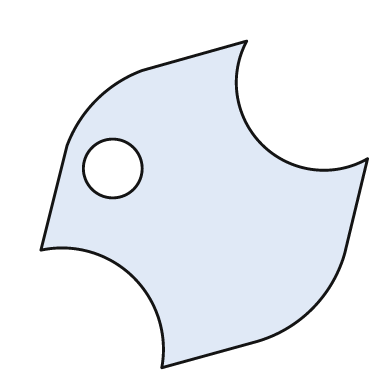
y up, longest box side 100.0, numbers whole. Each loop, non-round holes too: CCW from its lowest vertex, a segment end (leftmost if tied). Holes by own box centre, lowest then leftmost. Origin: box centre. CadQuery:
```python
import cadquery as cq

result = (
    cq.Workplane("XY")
    .moveTo(-13.0, -50.0)
    .lineTo(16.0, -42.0)
    .threePointArc((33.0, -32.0), (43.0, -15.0))
    .lineTo(50.0, 14.0)
    .threePointArc((18.0, 18.0), (13.0, 50.0))
    .lineTo(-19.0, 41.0)
    .threePointArc((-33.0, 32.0), (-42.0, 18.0))
    .lineTo(-50.0, -14.0)
    .threePointArc((-22.0, -22.0), (-13.0, -50.0))
    .close()
    .moveTo(-28.0, 11.0)
    .circle(9.0)
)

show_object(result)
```